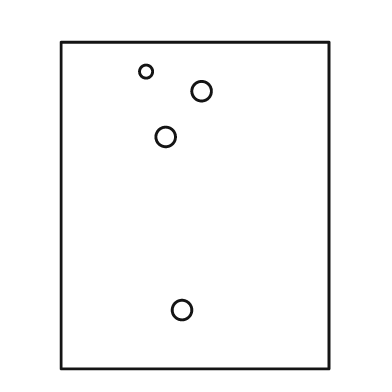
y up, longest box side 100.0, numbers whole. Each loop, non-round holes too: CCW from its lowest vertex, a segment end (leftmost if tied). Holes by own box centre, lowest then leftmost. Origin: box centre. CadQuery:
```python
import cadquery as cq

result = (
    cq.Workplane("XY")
    .moveTo(-41.0, -50.0)
    .lineTo(41.0, -50.0)
    .lineTo(41.0, 50.0)
    .lineTo(-41.0, 50.0)
    .close()
    .moveTo(-4.0, -32.0)
    .circle(3.0)
    .moveTo(-9.0, 21.0)
    .circle(3.0)
    .moveTo(2.0, 35.0)
    .circle(3.0)
    .moveTo(-15.0, 41.0)
    .circle(2.0)
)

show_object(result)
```